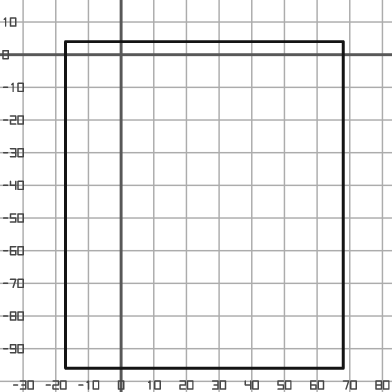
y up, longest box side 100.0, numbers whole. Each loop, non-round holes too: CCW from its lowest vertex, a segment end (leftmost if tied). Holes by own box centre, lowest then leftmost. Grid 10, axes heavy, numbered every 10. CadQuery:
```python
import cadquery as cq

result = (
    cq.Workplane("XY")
    .moveTo(-17.0, -96.0)
    .lineTo(68.0, -96.0)
    .lineTo(68.0, 4.0)
    .lineTo(-17.0, 4.0)
    .close()
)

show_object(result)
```